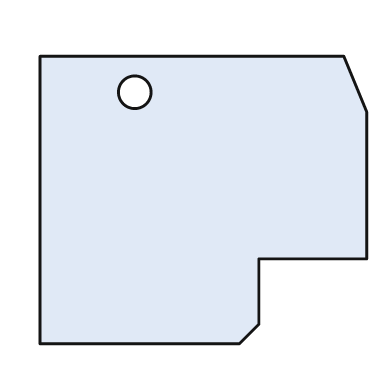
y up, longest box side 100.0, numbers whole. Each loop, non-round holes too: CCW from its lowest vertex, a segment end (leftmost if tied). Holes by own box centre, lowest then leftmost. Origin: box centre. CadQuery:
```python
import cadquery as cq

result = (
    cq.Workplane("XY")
    .moveTo(-50.0, -44.0)
    .lineTo(11.0, -44.0)
    .lineTo(17.0, -38.0)
    .lineTo(17.0, -18.0)
    .lineTo(50.0, -18.0)
    .lineTo(50.0, 27.0)
    .lineTo(43.0, 44.0)
    .lineTo(-50.0, 44.0)
    .close()
    .moveTo(-21.0, 33.0)
    .circle(5.0)
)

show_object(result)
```